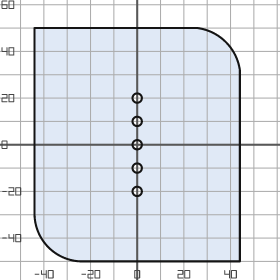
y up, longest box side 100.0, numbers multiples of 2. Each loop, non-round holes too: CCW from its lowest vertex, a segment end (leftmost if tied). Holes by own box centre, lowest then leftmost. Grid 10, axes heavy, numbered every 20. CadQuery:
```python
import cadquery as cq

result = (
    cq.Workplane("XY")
    .moveTo(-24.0, -50.0)
    .lineTo(44.0, -50.0)
    .lineTo(44.0, 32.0)
    .threePointArc((38.0, 44.0), (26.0, 50.0))
    .lineTo(-44.0, 50.0)
    .lineTo(-44.0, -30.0)
    .threePointArc((-38.0, -44.0), (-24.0, -50.0))
    .close()
    .moveTo(0.0, -20.0)
    .circle(2.0)
    .moveTo(0.0, -10.0)
    .circle(2.0)
    .moveTo(0.0, 0.0)
    .circle(2.0)
    .moveTo(0.0, 10.0)
    .circle(2.0)
    .moveTo(0.0, 20.0)
    .circle(2.0)
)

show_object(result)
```